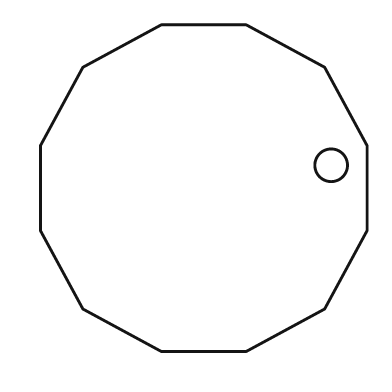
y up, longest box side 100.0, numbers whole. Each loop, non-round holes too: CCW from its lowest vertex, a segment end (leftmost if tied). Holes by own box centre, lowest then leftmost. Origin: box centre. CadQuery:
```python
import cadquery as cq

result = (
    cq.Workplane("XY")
    .moveTo(-13.0, -50.0)
    .lineTo(13.0, -50.0)
    .lineTo(37.0, -37.0)
    .lineTo(50.0, -13.0)
    .lineTo(50.0, 13.0)
    .lineTo(37.0, 37.0)
    .lineTo(13.0, 50.0)
    .lineTo(-13.0, 50.0)
    .lineTo(-37.0, 37.0)
    .lineTo(-50.0, 13.0)
    .lineTo(-50.0, -13.0)
    .lineTo(-37.0, -37.0)
    .close()
    .moveTo(39.0, 7.0)
    .circle(5.0)
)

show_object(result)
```